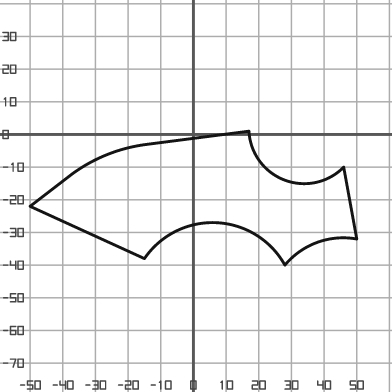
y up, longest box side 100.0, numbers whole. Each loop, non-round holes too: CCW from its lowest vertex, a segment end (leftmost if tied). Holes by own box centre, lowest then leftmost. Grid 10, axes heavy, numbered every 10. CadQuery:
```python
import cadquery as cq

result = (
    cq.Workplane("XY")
    .moveTo(28.0, -40.0)
    .threePointArc((38.0, -33.0), (50.0, -32.0))
    .lineTo(46.0, -10.0)
    .threePointArc((28.0, -14.0), (17.0, 1.0))
    .lineTo(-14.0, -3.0)
    .threePointArc((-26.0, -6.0), (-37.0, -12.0))
    .lineTo(-50.0, -22.0)
    .lineTo(-15.0, -38.0)
    .threePointArc((7.0, -27.0), (28.0, -40.0))
    .close()
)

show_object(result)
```